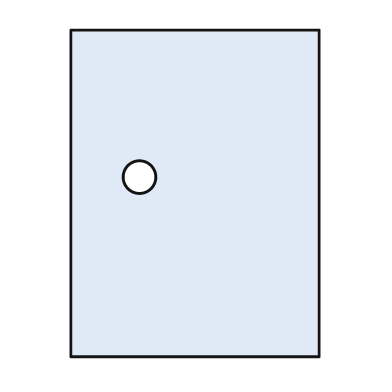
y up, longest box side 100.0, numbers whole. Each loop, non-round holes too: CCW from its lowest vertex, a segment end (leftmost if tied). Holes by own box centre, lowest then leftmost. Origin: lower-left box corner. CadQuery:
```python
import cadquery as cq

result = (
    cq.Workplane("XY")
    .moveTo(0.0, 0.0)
    .lineTo(76.0, 0.0)
    .lineTo(76.0, 100.0)
    .lineTo(0.0, 100.0)
    .close()
    .moveTo(21.0, 55.0)
    .circle(5.0)
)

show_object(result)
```